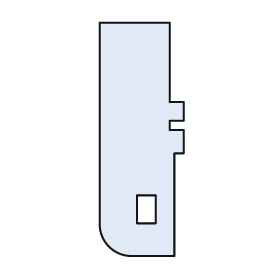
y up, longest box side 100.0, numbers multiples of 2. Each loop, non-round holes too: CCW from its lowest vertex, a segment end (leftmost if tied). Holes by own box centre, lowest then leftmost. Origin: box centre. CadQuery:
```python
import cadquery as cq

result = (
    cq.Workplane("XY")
    .moveTo(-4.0, -50.0)
    .lineTo(14.0, -50.0)
    .lineTo(14.0, -6.0)
    .lineTo(18.0, -6.0)
    .lineTo(18.0, 4.0)
    .lineTo(12.0, 4.0)
    .lineTo(12.0, 8.0)
    .lineTo(18.0, 8.0)
    .lineTo(18.0, 16.0)
    .lineTo(12.0, 16.0)
    .lineTo(12.0, 50.0)
    .lineTo(-18.0, 50.0)
    .lineTo(-18.0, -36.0)
    .threePointArc((-14.0, -46.0), (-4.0, -50.0))
    .close()
    .moveTo(-2.0, -36.0)
    .lineTo(6.0, -36.0)
    .lineTo(6.0, -24.0)
    .lineTo(-2.0, -24.0)
    .close()
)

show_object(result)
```